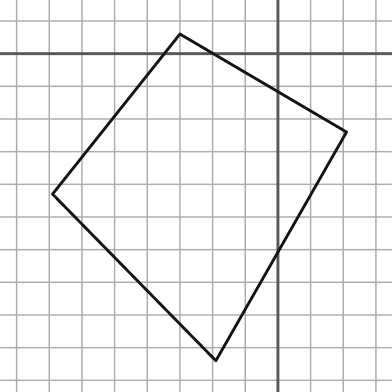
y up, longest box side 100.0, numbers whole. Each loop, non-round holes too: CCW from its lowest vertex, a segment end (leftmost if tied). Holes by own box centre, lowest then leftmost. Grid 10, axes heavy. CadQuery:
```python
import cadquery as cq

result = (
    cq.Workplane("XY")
    .moveTo(-19.0, -94.0)
    .lineTo(21.0, -24.0)
    .lineTo(-30.0, 6.0)
    .lineTo(-69.0, -43.0)
    .close()
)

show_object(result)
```